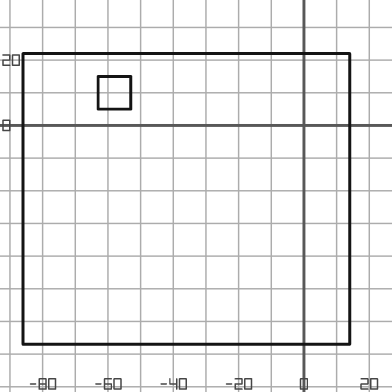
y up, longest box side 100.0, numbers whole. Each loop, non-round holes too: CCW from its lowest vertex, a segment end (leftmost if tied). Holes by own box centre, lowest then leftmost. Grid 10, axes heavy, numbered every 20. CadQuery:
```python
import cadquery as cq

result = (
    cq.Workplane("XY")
    .moveTo(-86.0, -67.0)
    .lineTo(14.0, -67.0)
    .lineTo(14.0, 22.0)
    .lineTo(-86.0, 22.0)
    .close()
    .moveTo(-63.0, 5.0)
    .lineTo(-53.0, 5.0)
    .lineTo(-53.0, 15.0)
    .lineTo(-63.0, 15.0)
    .close()
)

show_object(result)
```